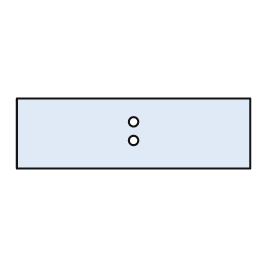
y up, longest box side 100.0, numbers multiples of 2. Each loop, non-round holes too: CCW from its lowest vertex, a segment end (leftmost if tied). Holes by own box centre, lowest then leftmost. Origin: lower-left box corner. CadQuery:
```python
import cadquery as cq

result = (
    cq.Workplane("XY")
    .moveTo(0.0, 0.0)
    .lineTo(100.0, 0.0)
    .lineTo(100.0, 30.0)
    .lineTo(0.0, 30.0)
    .close()
    .moveTo(50.0, 12.0)
    .circle(2.0)
    .moveTo(50.0, 20.0)
    .circle(2.0)
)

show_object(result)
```